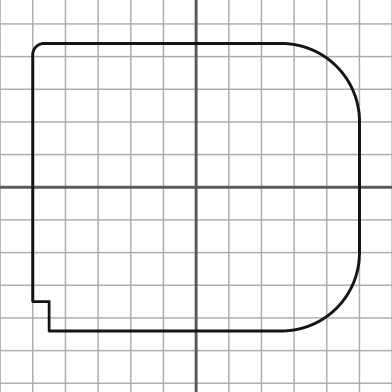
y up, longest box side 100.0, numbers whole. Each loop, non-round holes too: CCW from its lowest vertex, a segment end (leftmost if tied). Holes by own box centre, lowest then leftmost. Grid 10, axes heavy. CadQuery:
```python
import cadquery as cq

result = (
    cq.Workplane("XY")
    .moveTo(-45.0, -44.0)
    .lineTo(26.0, -44.0)
    .threePointArc((43.0, -37.0), (50.0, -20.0))
    .lineTo(50.0, 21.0)
    .threePointArc((43.0, 37.0), (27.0, 44.0))
    .lineTo(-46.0, 44.0)
    .threePointArc((-49.0, 43.0), (-50.0, 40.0))
    .lineTo(-50.0, -35.0)
    .lineTo(-45.0, -35.0)
    .close()
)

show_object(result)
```